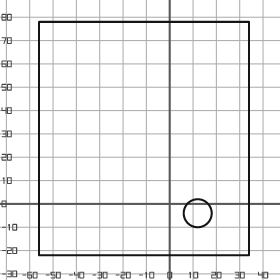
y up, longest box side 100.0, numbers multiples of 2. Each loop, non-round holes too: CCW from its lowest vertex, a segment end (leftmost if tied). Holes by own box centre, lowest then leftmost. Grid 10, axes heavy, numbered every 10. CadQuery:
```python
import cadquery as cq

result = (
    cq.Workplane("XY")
    .moveTo(-56.0, -22.0)
    .lineTo(34.0, -22.0)
    .lineTo(34.0, 78.0)
    .lineTo(-56.0, 78.0)
    .close()
    .moveTo(12.0, -4.0)
    .circle(6.0)
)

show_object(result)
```